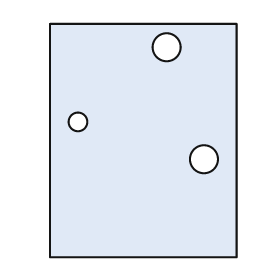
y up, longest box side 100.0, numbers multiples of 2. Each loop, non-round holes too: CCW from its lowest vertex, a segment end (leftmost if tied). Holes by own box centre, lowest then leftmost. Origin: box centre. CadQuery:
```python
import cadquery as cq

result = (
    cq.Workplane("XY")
    .moveTo(-40.0, -50.0)
    .lineTo(40.0, -50.0)
    .lineTo(40.0, 50.0)
    .lineTo(-40.0, 50.0)
    .close()
    .moveTo(26.0, -8.0)
    .circle(6.0)
    .moveTo(-28.0, 8.0)
    .circle(4.0)
    .moveTo(10.0, 40.0)
    .circle(6.0)
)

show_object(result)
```